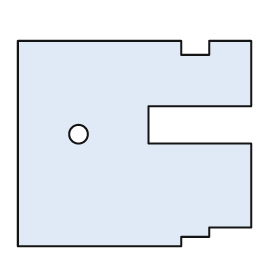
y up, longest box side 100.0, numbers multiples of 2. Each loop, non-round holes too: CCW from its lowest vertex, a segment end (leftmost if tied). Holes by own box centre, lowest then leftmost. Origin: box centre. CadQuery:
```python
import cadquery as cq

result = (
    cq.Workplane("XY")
    .moveTo(-50.0, -44.0)
    .lineTo(20.0, -44.0)
    .lineTo(20.0, -40.0)
    .lineTo(32.0, -40.0)
    .lineTo(32.0, -36.0)
    .lineTo(50.0, -36.0)
    .lineTo(50.0, 0.0)
    .lineTo(6.0, 0.0)
    .lineTo(6.0, 16.0)
    .lineTo(50.0, 16.0)
    .lineTo(50.0, 44.0)
    .lineTo(32.0, 44.0)
    .lineTo(32.0, 38.0)
    .lineTo(20.0, 38.0)
    .lineTo(20.0, 44.0)
    .lineTo(-50.0, 44.0)
    .close()
    .moveTo(-24.0, 4.0)
    .circle(4.0)
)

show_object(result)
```